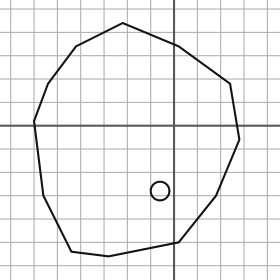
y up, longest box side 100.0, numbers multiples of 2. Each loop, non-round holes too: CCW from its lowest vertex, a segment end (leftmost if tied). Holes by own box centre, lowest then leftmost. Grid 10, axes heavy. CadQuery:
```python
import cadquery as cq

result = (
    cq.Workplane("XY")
    .moveTo(-28.0, -56.0)
    .lineTo(2.0, -50.0)
    .lineTo(18.0, -30.0)
    .lineTo(28.0, -6.0)
    .lineTo(24.0, 18.0)
    .lineTo(2.0, 34.0)
    .lineTo(-22.0, 44.0)
    .lineTo(-42.0, 34.0)
    .lineTo(-54.0, 18.0)
    .lineTo(-60.0, 2.0)
    .lineTo(-56.0, -30.0)
    .lineTo(-44.0, -54.0)
    .close()
    .moveTo(-6.0, -28.0)
    .circle(4.0)
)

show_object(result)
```